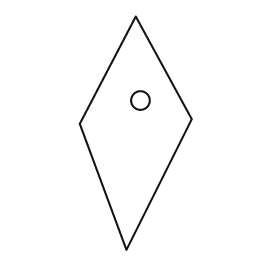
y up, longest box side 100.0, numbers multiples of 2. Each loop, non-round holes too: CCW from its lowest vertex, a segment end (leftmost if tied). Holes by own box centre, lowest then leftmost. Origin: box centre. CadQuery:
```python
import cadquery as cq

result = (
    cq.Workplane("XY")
    .moveTo(-4.0, -50.0)
    .lineTo(24.0, 6.0)
    .lineTo(0.0, 50.0)
    .lineTo(-24.0, 4.0)
    .close()
    .moveTo(2.0, 14.0)
    .circle(4.0)
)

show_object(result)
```